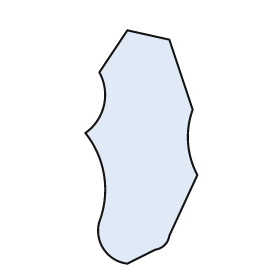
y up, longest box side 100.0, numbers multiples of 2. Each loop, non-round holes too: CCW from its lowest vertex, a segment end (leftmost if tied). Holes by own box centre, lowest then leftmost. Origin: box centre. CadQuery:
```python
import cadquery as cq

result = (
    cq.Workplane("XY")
    .moveTo(-6.0, -50.0)
    .lineTo(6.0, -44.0)
    .threePointArc((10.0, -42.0), (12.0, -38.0))
    .lineTo(24.0, -12.0)
    .threePointArc((20.0, 2.0), (22.0, 16.0))
    .lineTo(12.0, 46.0)
    .lineTo(-6.0, 50.0)
    .lineTo(-18.0, 32.0)
    .threePointArc((-16.0, 18.0), (-24.0, 6.0))
    .threePointArc((-16.0, -12.0), (-18.0, -32.0))
    .threePointArc((-16.0, -44.0), (-6.0, -50.0))
    .close()
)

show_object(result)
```